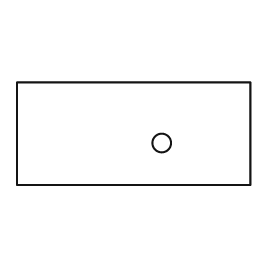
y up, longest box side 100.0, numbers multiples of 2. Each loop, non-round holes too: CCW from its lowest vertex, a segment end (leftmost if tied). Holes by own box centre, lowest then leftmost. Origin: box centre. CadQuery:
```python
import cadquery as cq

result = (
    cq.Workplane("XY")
    .moveTo(-50.0, -22.0)
    .lineTo(50.0, -22.0)
    .lineTo(50.0, 22.0)
    .lineTo(-50.0, 22.0)
    .close()
    .moveTo(12.0, -4.0)
    .circle(4.0)
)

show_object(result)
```